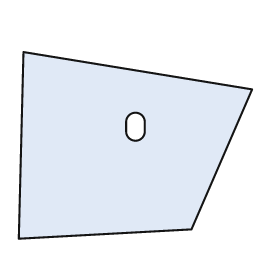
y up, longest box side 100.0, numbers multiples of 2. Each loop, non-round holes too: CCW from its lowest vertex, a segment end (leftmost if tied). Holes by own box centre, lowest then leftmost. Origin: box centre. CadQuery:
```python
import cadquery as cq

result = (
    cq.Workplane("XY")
    .moveTo(-50.0, -40.0)
    .lineTo(24.0, -36.0)
    .lineTo(50.0, 24.0)
    .lineTo(-48.0, 40.0)
    .close()
    .moveTo(-4.0, 6.0)
    .threePointArc((0.0, 2.0), (4.0, 6.0))
    .lineTo(4.0, 10.0)
    .threePointArc((0.0, 14.0), (-4.0, 10.0))
    .close()
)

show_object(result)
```